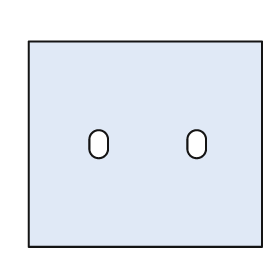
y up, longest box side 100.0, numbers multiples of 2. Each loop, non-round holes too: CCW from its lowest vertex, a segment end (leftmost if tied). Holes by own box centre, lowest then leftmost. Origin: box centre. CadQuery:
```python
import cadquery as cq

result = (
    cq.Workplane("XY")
    .moveTo(-50.0, -44.0)
    .lineTo(50.0, -44.0)
    .lineTo(50.0, 44.0)
    .lineTo(-50.0, 44.0)
    .close()
    .moveTo(-24.0, -2.0)
    .threePointArc((-20.0, -6.0), (-16.0, -2.0))
    .lineTo(-16.0, 2.0)
    .threePointArc((-20.0, 6.0), (-24.0, 2.0))
    .close()
    .moveTo(18.0, -2.0)
    .threePointArc((22.0, -6.0), (26.0, -2.0))
    .lineTo(26.0, 2.0)
    .threePointArc((22.0, 6.0), (18.0, 2.0))
    .close()
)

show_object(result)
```